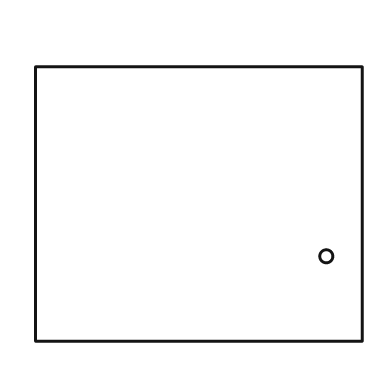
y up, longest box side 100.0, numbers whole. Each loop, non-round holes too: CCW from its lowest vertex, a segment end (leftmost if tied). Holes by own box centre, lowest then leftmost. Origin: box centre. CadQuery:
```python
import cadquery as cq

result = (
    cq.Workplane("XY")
    .moveTo(-50.0, -42.0)
    .lineTo(50.0, -42.0)
    .lineTo(50.0, 42.0)
    .lineTo(-50.0, 42.0)
    .close()
    .moveTo(39.0, -16.0)
    .circle(2.0)
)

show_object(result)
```